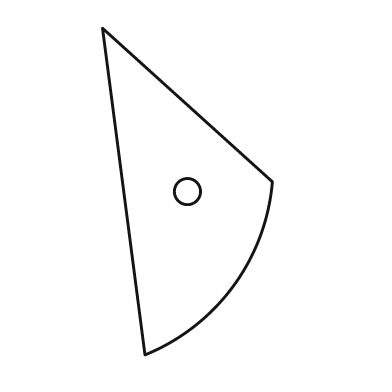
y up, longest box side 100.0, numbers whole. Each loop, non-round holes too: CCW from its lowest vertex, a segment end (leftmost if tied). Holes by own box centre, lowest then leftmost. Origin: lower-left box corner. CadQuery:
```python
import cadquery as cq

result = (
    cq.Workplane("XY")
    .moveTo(13.0, 0.0)
    .threePointArc((40.0, 21.0), (52.0, 53.0))
    .lineTo(0.0, 100.0)
    .close()
    .moveTo(26.0, 50.0)
    .circle(4.0)
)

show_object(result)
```